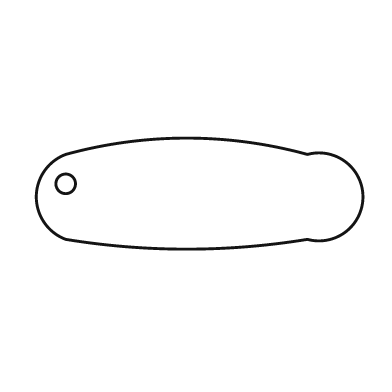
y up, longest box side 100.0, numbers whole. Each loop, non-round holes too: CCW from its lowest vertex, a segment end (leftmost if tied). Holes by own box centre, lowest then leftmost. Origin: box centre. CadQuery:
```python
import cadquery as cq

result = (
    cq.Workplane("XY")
    .moveTo(-41.0, -14.0)
    .threePointArc((-4.0, -17.0), (33.0, -14.0))
    .threePointArc((50.0, -1.0), (33.0, 12.0))
    .threePointArc((-4.0, 17.0), (-41.0, 12.0))
    .threePointArc((-50.0, -1.0), (-41.0, -14.0))
    .close()
    .moveTo(-41.0, 3.0)
    .circle(3.0)
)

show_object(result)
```